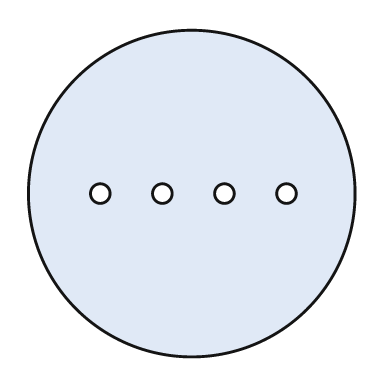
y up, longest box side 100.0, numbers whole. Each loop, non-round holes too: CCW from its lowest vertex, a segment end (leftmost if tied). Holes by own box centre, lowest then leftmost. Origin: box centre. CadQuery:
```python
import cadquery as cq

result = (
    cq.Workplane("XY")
    .moveTo(0.0, 0.0)
    .circle(50.0)
    .moveTo(-28.0, 0.0)
    .circle(3.0)
    .moveTo(-9.0, 0.0)
    .circle(3.0)
    .moveTo(10.0, 0.0)
    .circle(3.0)
    .moveTo(29.0, 0.0)
    .circle(3.0)
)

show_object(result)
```